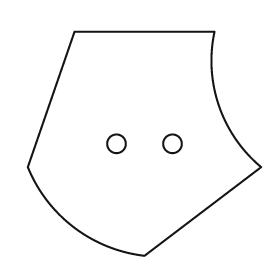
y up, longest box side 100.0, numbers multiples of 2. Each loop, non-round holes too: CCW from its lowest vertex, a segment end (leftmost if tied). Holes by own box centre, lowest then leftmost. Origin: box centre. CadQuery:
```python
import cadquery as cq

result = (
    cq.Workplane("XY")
    .moveTo(0.0, -48.0)
    .lineTo(50.0, -10.0)
    .threePointArc((32.0, 16.0), (30.0, 48.0))
    .lineTo(-30.0, 48.0)
    .lineTo(-50.0, -10.0)
    .threePointArc((-30.0, -36.0), (0.0, -48.0))
    .close()
    .moveTo(-12.0, 0.0)
    .circle(4.0)
    .moveTo(12.0, 0.0)
    .circle(4.0)
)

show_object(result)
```